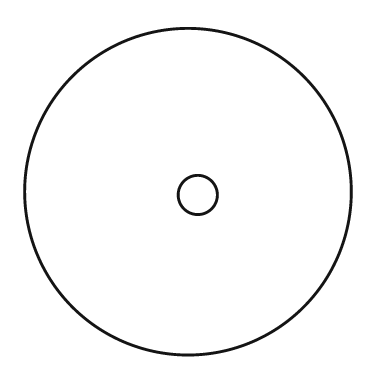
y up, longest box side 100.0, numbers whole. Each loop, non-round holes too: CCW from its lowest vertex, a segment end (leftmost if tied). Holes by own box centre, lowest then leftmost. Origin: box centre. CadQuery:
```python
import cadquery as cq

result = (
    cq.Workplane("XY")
    .moveTo(0.0, 0.0)
    .circle(50.0)
    .moveTo(3.0, -1.0)
    .circle(6.0)
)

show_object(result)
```